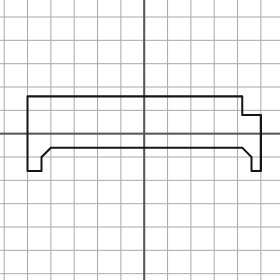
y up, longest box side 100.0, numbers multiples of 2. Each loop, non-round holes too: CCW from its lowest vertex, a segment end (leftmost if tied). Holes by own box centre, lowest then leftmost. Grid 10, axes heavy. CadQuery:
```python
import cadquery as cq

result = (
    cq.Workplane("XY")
    .moveTo(-50.0, -16.0)
    .lineTo(-44.0, -16.0)
    .lineTo(-44.0, -10.0)
    .lineTo(-40.0, -6.0)
    .lineTo(42.0, -6.0)
    .lineTo(46.0, -10.0)
    .lineTo(46.0, -16.0)
    .lineTo(50.0, -16.0)
    .lineTo(50.0, 8.0)
    .lineTo(42.0, 8.0)
    .lineTo(42.0, 16.0)
    .lineTo(-50.0, 16.0)
    .close()
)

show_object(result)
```